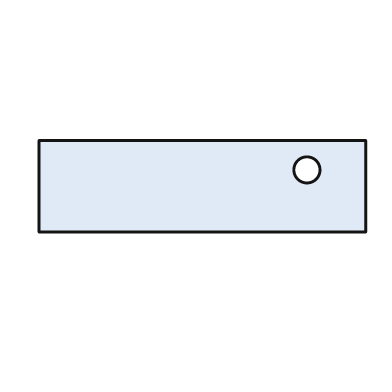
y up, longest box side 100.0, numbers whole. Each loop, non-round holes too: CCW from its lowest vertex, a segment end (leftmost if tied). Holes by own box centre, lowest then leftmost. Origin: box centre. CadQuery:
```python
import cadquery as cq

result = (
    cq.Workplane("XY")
    .moveTo(-50.0, -14.0)
    .lineTo(50.0, -14.0)
    .lineTo(50.0, 14.0)
    .lineTo(-50.0, 14.0)
    .close()
    .moveTo(32.0, 5.0)
    .circle(4.0)
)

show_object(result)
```